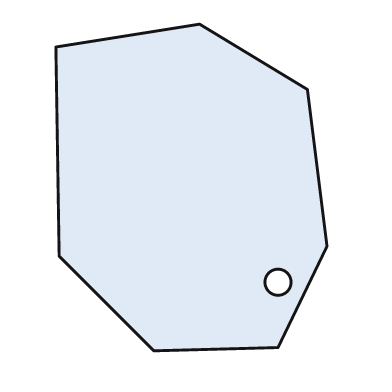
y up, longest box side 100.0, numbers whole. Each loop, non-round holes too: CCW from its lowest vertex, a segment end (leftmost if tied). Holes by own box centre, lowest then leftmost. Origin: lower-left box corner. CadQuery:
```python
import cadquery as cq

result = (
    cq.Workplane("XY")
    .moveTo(30.0, 0.0)
    .lineTo(68.0, 1.0)
    .lineTo(83.0, 32.0)
    .lineTo(77.0, 80.0)
    .lineTo(44.0, 100.0)
    .lineTo(0.0, 93.0)
    .lineTo(1.0, 29.0)
    .close()
    .moveTo(68.0, 21.0)
    .circle(4.0)
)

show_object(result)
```